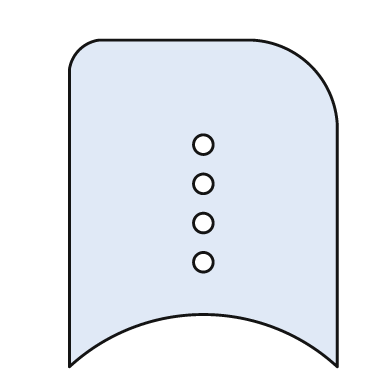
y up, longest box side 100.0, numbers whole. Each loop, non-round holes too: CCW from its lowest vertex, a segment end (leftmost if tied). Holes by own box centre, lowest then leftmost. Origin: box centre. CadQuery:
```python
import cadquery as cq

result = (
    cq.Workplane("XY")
    .moveTo(-41.0, -50.0)
    .threePointArc((0.0, -34.0), (41.0, -50.0))
    .lineTo(41.0, 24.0)
    .threePointArc((33.0, 42.0), (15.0, 50.0))
    .lineTo(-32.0, 50.0)
    .threePointArc((-38.0, 47.0), (-41.0, 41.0))
    .close()
    .moveTo(0.0, -18.0)
    .circle(3.0)
    .moveTo(0.0, -6.0)
    .circle(3.0)
    .moveTo(0.0, 6.0)
    .circle(3.0)
    .moveTo(0.0, 18.0)
    .circle(3.0)
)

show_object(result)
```